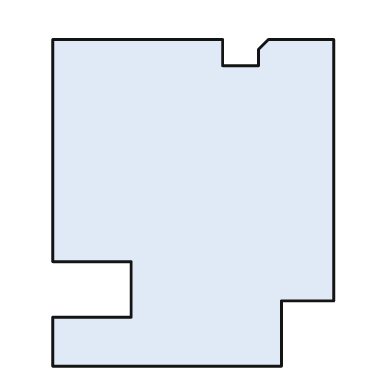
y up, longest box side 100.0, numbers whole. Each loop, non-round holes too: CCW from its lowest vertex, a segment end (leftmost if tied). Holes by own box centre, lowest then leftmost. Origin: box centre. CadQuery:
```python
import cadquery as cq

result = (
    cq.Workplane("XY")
    .moveTo(-43.0, -50.0)
    .lineTo(27.0, -50.0)
    .lineTo(27.0, -30.0)
    .lineTo(43.0, -30.0)
    .lineTo(43.0, 50.0)
    .lineTo(23.0, 50.0)
    .lineTo(20.0, 47.0)
    .lineTo(20.0, 42.0)
    .lineTo(9.0, 42.0)
    .lineTo(9.0, 50.0)
    .lineTo(-43.0, 50.0)
    .lineTo(-43.0, -18.0)
    .lineTo(-19.0, -18.0)
    .lineTo(-19.0, -35.0)
    .lineTo(-43.0, -35.0)
    .close()
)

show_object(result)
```